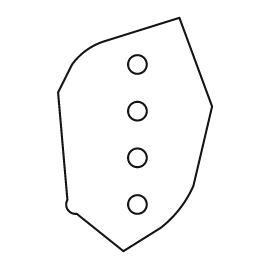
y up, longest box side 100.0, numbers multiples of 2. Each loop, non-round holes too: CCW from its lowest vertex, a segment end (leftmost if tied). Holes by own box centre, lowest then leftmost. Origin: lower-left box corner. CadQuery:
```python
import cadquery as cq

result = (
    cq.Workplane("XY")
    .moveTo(28.0, 0.0)
    .lineTo(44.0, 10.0)
    .threePointArc((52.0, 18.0), (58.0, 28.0))
    .lineTo(66.0, 62.0)
    .lineTo(52.0, 100.0)
    .lineTo(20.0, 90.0)
    .threePointArc((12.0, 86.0), (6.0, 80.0))
    .lineTo(0.0, 68.0)
    .lineTo(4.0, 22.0)
    .threePointArc((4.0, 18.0), (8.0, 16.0))
    .close()
    .moveTo(34.0, 20.0)
    .circle(4.0)
    .moveTo(34.0, 40.0)
    .circle(4.0)
    .moveTo(34.0, 60.0)
    .circle(4.0)
    .moveTo(34.0, 80.0)
    .circle(4.0)
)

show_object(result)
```